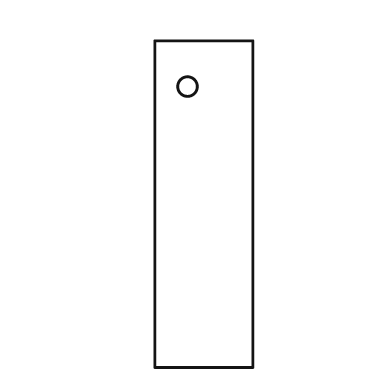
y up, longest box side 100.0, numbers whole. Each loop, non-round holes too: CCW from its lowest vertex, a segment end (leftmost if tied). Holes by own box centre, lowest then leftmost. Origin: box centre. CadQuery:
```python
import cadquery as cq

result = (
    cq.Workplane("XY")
    .moveTo(-15.0, -50.0)
    .lineTo(15.0, -50.0)
    .lineTo(15.0, 50.0)
    .lineTo(-15.0, 50.0)
    .close()
    .moveTo(-5.0, 36.0)
    .circle(3.0)
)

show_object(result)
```